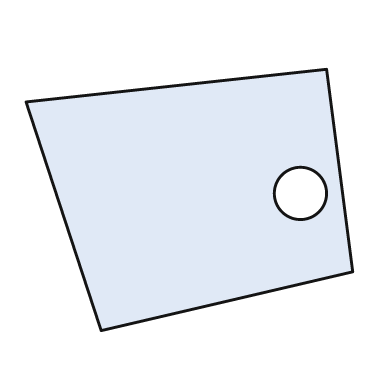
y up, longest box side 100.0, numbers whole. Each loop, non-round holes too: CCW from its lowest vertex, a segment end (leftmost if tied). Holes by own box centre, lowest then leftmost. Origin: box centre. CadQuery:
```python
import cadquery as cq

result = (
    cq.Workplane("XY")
    .moveTo(-27.0, -40.0)
    .lineTo(50.0, -22.0)
    .lineTo(42.0, 40.0)
    .lineTo(-50.0, 30.0)
    .close()
    .moveTo(34.0, 2.0)
    .circle(8.0)
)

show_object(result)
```